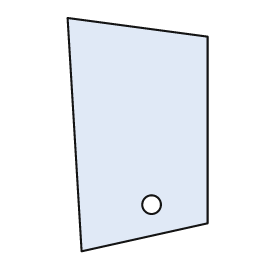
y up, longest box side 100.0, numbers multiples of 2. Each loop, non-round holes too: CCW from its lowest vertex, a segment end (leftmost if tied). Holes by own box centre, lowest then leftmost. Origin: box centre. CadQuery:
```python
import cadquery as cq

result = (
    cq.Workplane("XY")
    .moveTo(-24.0, -50.0)
    .lineTo(30.0, -38.0)
    .lineTo(30.0, 42.0)
    .lineTo(-30.0, 50.0)
    .close()
    .moveTo(6.0, -30.0)
    .circle(4.0)
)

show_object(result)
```